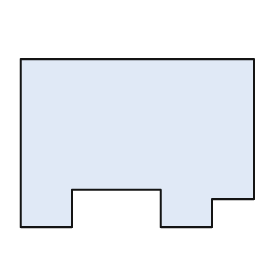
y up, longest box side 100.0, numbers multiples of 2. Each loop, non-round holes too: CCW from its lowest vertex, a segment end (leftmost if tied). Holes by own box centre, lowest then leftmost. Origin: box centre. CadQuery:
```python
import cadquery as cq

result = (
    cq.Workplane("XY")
    .moveTo(-50.0, -36.0)
    .lineTo(-28.0, -36.0)
    .lineTo(-28.0, -20.0)
    .lineTo(10.0, -20.0)
    .lineTo(10.0, -36.0)
    .lineTo(32.0, -36.0)
    .lineTo(32.0, -24.0)
    .lineTo(50.0, -24.0)
    .lineTo(50.0, 36.0)
    .lineTo(-50.0, 36.0)
    .close()
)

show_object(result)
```